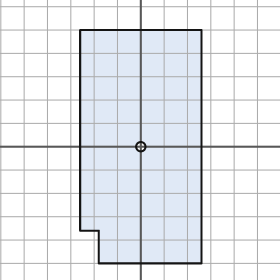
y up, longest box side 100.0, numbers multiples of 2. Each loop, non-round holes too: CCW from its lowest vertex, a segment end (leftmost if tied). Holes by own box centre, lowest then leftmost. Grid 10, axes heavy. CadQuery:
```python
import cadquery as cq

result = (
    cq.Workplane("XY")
    .moveTo(-18.0, -50.0)
    .lineTo(26.0, -50.0)
    .lineTo(26.0, 50.0)
    .lineTo(-26.0, 50.0)
    .lineTo(-26.0, -36.0)
    .lineTo(-18.0, -36.0)
    .close()
    .moveTo(0.0, 0.0)
    .circle(2.0)
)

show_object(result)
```